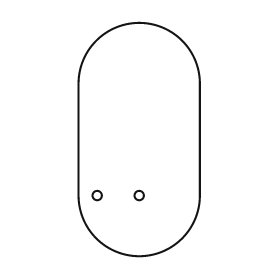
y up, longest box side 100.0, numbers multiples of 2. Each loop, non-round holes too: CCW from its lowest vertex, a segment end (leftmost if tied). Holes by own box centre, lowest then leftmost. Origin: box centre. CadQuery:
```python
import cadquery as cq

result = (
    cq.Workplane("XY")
    .moveTo(-26.0, -24.0)
    .threePointArc((0.0, -50.0), (26.0, -24.0))
    .lineTo(26.0, 24.0)
    .threePointArc((0.0, 50.0), (-26.0, 24.0))
    .close()
    .moveTo(-18.0, -24.0)
    .circle(2.0)
    .moveTo(0.0, -24.0)
    .circle(2.0)
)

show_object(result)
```